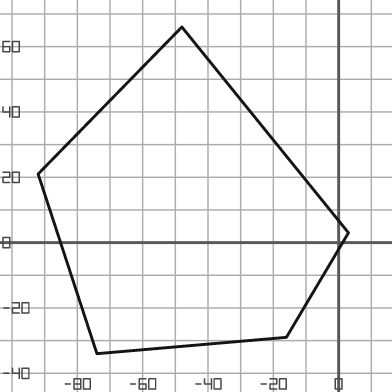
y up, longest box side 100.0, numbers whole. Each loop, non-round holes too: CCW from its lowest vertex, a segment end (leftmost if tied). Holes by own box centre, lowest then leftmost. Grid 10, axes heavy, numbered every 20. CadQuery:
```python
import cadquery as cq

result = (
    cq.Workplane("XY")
    .moveTo(-74.0, -34.0)
    .lineTo(-16.0, -29.0)
    .lineTo(3.0, 3.0)
    .lineTo(-48.0, 66.0)
    .lineTo(-92.0, 21.0)
    .close()
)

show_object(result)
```